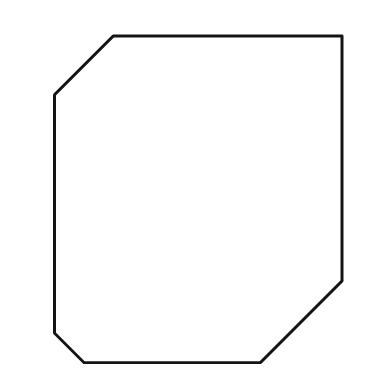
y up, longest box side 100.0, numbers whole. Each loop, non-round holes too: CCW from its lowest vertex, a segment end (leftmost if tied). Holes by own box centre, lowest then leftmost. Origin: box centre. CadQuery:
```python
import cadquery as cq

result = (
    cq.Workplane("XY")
    .moveTo(-35.0, -50.0)
    .lineTo(19.0, -50.0)
    .lineTo(44.0, -25.0)
    .lineTo(44.0, 50.0)
    .lineTo(-26.0, 50.0)
    .lineTo(-44.0, 32.0)
    .lineTo(-44.0, -41.0)
    .close()
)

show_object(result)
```